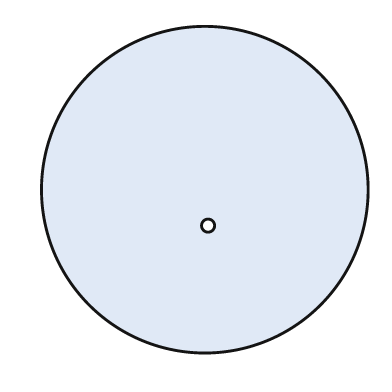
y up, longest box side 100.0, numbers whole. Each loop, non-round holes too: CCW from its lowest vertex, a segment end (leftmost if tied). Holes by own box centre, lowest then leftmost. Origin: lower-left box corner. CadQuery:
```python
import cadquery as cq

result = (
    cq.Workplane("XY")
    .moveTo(50.0, 50.0)
    .circle(50.0)
    .moveTo(51.0, 39.0)
    .circle(2.0)
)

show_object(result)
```